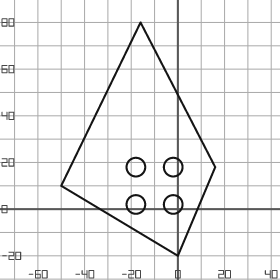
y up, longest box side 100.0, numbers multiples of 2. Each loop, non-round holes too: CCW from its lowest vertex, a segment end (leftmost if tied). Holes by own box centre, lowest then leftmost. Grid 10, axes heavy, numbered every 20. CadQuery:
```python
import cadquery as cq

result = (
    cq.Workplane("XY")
    .moveTo(0.0, -20.0)
    .lineTo(16.0, 18.0)
    .lineTo(-16.0, 80.0)
    .lineTo(-50.0, 10.0)
    .close()
    .moveTo(-18.0, 2.0)
    .circle(4.0)
    .moveTo(-2.0, 2.0)
    .circle(4.0)
    .moveTo(-18.0, 18.0)
    .circle(4.0)
    .moveTo(-2.0, 18.0)
    .circle(4.0)
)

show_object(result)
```